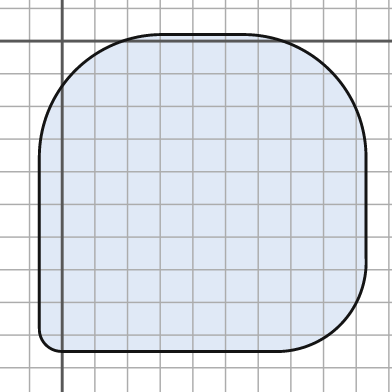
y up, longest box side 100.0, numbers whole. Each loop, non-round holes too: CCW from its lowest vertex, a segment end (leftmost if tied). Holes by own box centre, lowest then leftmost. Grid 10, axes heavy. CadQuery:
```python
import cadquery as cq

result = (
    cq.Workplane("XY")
    .moveTo(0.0, -95.0)
    .lineTo(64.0, -95.0)
    .threePointArc((85.0, -87.0), (93.0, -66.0))
    .lineTo(93.0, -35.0)
    .threePointArc((82.0, -9.0), (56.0, 2.0))
    .lineTo(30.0, 2.0)
    .threePointArc((4.0, -9.0), (-7.0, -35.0))
    .lineTo(-7.0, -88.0)
    .threePointArc((-5.0, -93.0), (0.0, -95.0))
    .close()
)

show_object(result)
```